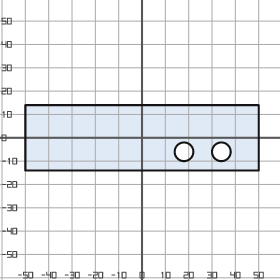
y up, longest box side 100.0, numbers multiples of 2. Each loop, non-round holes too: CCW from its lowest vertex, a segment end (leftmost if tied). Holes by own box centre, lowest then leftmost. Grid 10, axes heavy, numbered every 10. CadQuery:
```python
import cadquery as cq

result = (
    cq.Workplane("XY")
    .moveTo(-50.0, -14.0)
    .lineTo(50.0, -14.0)
    .lineTo(50.0, 14.0)
    .lineTo(-50.0, 14.0)
    .close()
    .moveTo(18.0, -6.0)
    .circle(4.0)
    .moveTo(34.0, -6.0)
    .circle(4.0)
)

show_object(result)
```